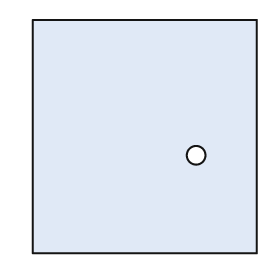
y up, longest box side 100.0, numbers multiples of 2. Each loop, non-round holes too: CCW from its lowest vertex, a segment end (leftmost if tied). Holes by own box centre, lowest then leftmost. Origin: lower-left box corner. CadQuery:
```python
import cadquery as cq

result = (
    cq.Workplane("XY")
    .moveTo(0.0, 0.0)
    .lineTo(96.0, 0.0)
    .lineTo(96.0, 100.0)
    .lineTo(0.0, 100.0)
    .close()
    .moveTo(70.0, 42.0)
    .circle(4.0)
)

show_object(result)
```